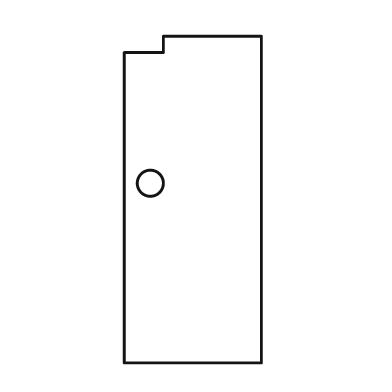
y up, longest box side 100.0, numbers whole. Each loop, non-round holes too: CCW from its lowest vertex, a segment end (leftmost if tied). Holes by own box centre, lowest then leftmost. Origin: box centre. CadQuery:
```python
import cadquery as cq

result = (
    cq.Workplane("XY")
    .moveTo(-21.0, -50.0)
    .lineTo(21.0, -50.0)
    .lineTo(21.0, 50.0)
    .lineTo(-9.0, 50.0)
    .lineTo(-9.0, 45.0)
    .lineTo(-21.0, 45.0)
    .close()
    .moveTo(-13.0, 5.0)
    .circle(4.0)
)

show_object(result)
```